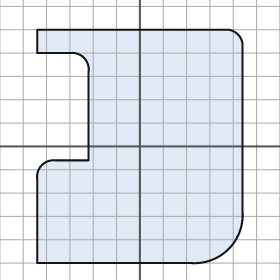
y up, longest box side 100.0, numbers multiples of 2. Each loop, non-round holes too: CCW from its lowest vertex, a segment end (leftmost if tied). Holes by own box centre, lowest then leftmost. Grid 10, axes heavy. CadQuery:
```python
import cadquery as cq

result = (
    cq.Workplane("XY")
    .moveTo(-44.0, -50.0)
    .lineTo(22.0, -50.0)
    .threePointArc((38.0, -44.0), (44.0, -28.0))
    .lineTo(44.0, 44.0)
    .threePointArc((42.0, 48.0), (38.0, 50.0))
    .lineTo(-44.0, 50.0)
    .lineTo(-44.0, 40.0)
    .lineTo(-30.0, 40.0)
    .threePointArc((-24.0, 38.0), (-22.0, 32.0))
    .lineTo(-22.0, -6.0)
    .lineTo(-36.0, -6.0)
    .threePointArc((-42.0, -8.0), (-44.0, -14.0))
    .close()
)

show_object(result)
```